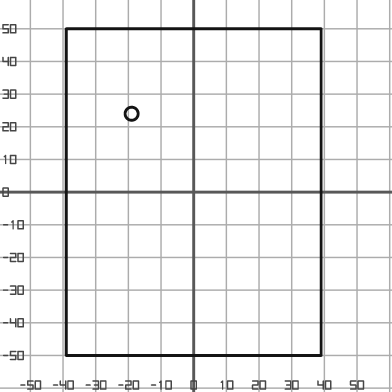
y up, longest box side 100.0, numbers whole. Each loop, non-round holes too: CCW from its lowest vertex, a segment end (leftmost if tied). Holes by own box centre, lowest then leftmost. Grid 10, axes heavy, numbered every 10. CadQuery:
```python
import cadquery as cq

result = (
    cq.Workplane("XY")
    .moveTo(-39.0, -50.0)
    .lineTo(39.0, -50.0)
    .lineTo(39.0, 50.0)
    .lineTo(-39.0, 50.0)
    .close()
    .moveTo(-19.0, 24.0)
    .circle(2.0)
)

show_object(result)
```